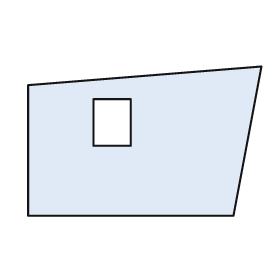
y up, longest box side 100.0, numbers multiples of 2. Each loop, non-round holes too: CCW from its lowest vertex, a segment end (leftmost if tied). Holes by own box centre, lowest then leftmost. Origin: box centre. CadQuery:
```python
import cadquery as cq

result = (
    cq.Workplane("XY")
    .moveTo(-50.0, -32.0)
    .lineTo(38.0, -32.0)
    .lineTo(50.0, 32.0)
    .lineTo(-50.0, 24.0)
    .close()
    .moveTo(-22.0, -2.0)
    .lineTo(-6.0, -2.0)
    .lineTo(-6.0, 18.0)
    .lineTo(-22.0, 18.0)
    .close()
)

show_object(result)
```